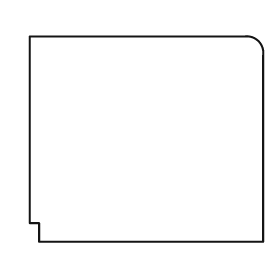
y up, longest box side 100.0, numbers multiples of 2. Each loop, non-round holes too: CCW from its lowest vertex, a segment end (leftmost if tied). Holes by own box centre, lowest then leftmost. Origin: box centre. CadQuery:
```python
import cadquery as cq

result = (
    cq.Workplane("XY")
    .moveTo(-46.0, -44.0)
    .lineTo(50.0, -44.0)
    .lineTo(50.0, 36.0)
    .threePointArc((48.0, 42.0), (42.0, 44.0))
    .lineTo(-50.0, 44.0)
    .lineTo(-50.0, -36.0)
    .lineTo(-46.0, -36.0)
    .close()
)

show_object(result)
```